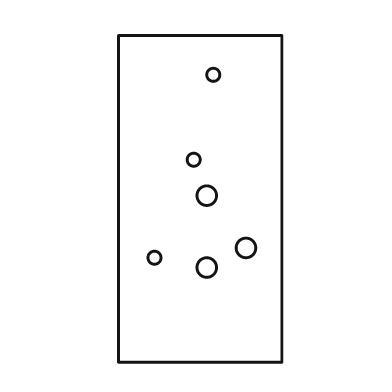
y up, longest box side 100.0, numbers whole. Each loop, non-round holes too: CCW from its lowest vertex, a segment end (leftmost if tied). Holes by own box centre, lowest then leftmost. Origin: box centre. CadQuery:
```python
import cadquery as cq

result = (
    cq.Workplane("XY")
    .moveTo(-25.0, -50.0)
    .lineTo(25.0, -50.0)
    .lineTo(25.0, 50.0)
    .lineTo(-25.0, 50.0)
    .close()
    .moveTo(2.0, -21.0)
    .circle(3.0)
    .moveTo(-14.0, -18.0)
    .circle(2.0)
    .moveTo(14.0, -15.0)
    .circle(3.0)
    .moveTo(2.0, 1.0)
    .circle(3.0)
    .moveTo(-2.0, 12.0)
    .circle(2.0)
    .moveTo(4.0, 38.0)
    .circle(2.0)
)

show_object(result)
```